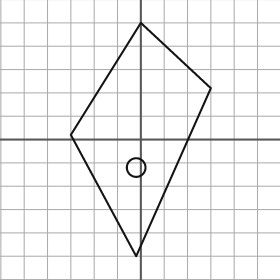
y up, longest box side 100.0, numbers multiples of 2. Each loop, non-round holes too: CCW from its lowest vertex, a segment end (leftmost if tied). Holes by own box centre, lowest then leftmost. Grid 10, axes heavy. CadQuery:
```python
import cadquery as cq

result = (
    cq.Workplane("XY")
    .moveTo(-2.0, -50.0)
    .lineTo(30.0, 22.0)
    .lineTo(0.0, 50.0)
    .lineTo(-30.0, 2.0)
    .close()
    .moveTo(-2.0, -12.0)
    .circle(4.0)
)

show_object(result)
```